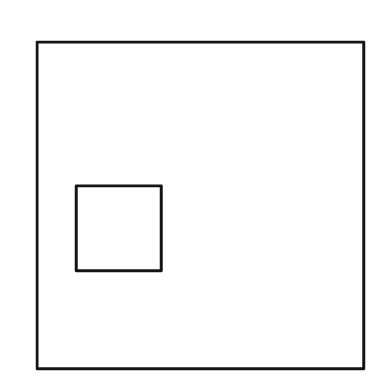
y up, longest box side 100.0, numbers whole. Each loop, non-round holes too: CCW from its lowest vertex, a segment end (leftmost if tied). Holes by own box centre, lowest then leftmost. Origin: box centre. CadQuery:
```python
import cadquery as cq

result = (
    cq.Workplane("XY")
    .moveTo(-50.0, -50.0)
    .lineTo(50.0, -50.0)
    .lineTo(50.0, 50.0)
    .lineTo(-50.0, 50.0)
    .close()
    .moveTo(-38.0, -20.0)
    .lineTo(-12.0, -20.0)
    .lineTo(-12.0, 6.0)
    .lineTo(-38.0, 6.0)
    .close()
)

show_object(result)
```